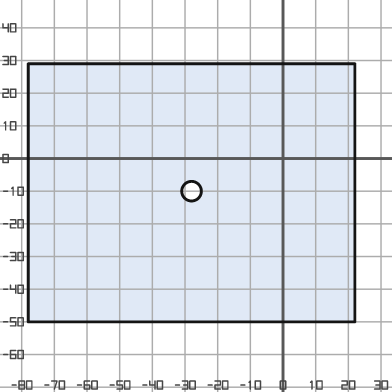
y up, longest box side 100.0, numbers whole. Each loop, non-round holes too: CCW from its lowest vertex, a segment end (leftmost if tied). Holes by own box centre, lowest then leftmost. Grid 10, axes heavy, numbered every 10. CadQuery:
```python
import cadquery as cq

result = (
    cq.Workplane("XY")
    .moveTo(-78.0, -50.0)
    .lineTo(22.0, -50.0)
    .lineTo(22.0, 29.0)
    .lineTo(-78.0, 29.0)
    .close()
    .moveTo(-28.0, -10.0)
    .circle(3.0)
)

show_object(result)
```